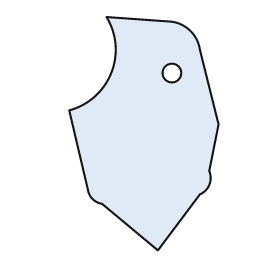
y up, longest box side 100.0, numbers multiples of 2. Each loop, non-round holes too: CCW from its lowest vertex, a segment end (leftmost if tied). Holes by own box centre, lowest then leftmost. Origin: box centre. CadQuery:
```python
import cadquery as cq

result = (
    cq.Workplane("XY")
    .moveTo(6.0, -50.0)
    .lineTo(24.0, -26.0)
    .threePointArc((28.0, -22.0), (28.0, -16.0))
    .lineTo(32.0, 4.0)
    .lineTo(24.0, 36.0)
    .threePointArc((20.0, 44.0), (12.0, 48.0))
    .lineTo(-16.0, 50.0)
    .threePointArc((-14.0, 26.0), (-32.0, 10.0))
    .lineTo(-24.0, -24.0)
    .threePointArc((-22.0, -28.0), (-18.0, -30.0))
    .close()
    .moveTo(12.0, 26.0)
    .circle(4.0)
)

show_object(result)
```